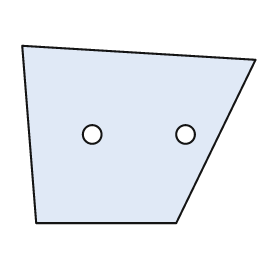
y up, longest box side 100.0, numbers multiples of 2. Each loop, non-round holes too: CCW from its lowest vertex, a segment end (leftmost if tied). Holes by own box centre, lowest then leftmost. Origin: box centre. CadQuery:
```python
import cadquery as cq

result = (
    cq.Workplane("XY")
    .moveTo(-44.0, -38.0)
    .lineTo(16.0, -38.0)
    .lineTo(50.0, 32.0)
    .lineTo(-50.0, 38.0)
    .close()
    .moveTo(-20.0, 0.0)
    .circle(4.0)
    .moveTo(20.0, 0.0)
    .circle(4.0)
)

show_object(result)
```